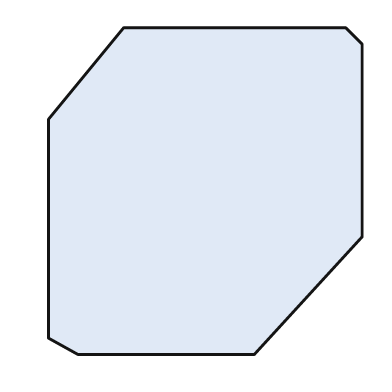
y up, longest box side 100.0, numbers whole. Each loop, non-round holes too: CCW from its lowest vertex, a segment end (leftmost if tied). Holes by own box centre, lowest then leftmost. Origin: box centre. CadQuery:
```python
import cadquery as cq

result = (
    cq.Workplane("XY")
    .moveTo(-39.0, -50.0)
    .lineTo(15.0, -50.0)
    .lineTo(48.0, -14.0)
    .lineTo(48.0, 45.0)
    .lineTo(43.0, 50.0)
    .lineTo(-25.0, 50.0)
    .lineTo(-48.0, 22.0)
    .lineTo(-48.0, -45.0)
    .close()
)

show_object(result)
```